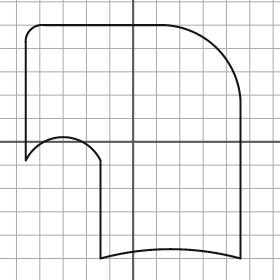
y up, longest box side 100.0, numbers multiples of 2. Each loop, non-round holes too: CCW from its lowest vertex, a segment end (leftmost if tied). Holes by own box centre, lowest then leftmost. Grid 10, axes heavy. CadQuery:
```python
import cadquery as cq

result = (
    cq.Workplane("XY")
    .moveTo(-14.0, -50.0)
    .threePointArc((16.0, -46.0), (46.0, -50.0))
    .lineTo(46.0, 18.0)
    .threePointArc((36.0, 40.0), (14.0, 50.0))
    .lineTo(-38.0, 50.0)
    .threePointArc((-44.0, 48.0), (-46.0, 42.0))
    .lineTo(-46.0, -8.0)
    .threePointArc((-30.0, 2.0), (-14.0, -8.0))
    .close()
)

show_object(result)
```